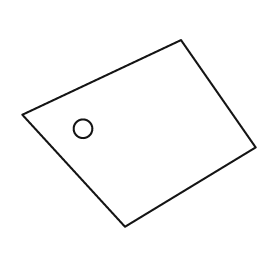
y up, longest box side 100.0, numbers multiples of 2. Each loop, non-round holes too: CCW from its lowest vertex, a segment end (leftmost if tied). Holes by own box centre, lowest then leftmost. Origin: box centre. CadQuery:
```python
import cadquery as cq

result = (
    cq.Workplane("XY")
    .moveTo(-6.0, -40.0)
    .lineTo(50.0, -6.0)
    .lineTo(18.0, 40.0)
    .lineTo(-50.0, 8.0)
    .close()
    .moveTo(-24.0, 2.0)
    .circle(4.0)
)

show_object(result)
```